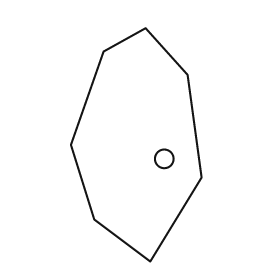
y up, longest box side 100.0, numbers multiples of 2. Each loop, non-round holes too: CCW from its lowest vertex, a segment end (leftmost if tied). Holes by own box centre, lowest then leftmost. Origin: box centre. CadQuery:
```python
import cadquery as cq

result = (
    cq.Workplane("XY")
    .moveTo(6.0, -50.0)
    .lineTo(28.0, -14.0)
    .lineTo(22.0, 30.0)
    .lineTo(4.0, 50.0)
    .lineTo(-14.0, 40.0)
    .lineTo(-28.0, 0.0)
    .lineTo(-18.0, -32.0)
    .close()
    .moveTo(12.0, -6.0)
    .circle(4.0)
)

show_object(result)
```